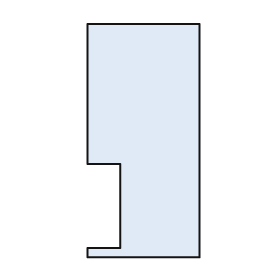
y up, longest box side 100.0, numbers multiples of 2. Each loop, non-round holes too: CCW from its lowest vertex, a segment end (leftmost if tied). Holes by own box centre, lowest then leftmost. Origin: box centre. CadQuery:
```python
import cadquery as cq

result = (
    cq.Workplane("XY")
    .moveTo(-24.0, -50.0)
    .lineTo(24.0, -50.0)
    .lineTo(24.0, 50.0)
    .lineTo(-24.0, 50.0)
    .lineTo(-24.0, -10.0)
    .lineTo(-10.0, -10.0)
    .lineTo(-10.0, -46.0)
    .lineTo(-24.0, -46.0)
    .close()
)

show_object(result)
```